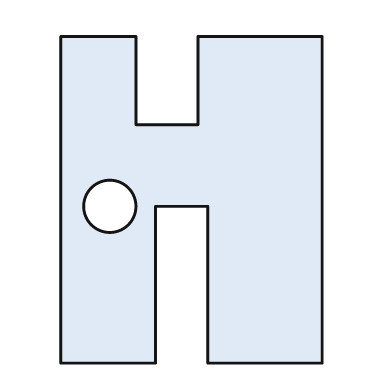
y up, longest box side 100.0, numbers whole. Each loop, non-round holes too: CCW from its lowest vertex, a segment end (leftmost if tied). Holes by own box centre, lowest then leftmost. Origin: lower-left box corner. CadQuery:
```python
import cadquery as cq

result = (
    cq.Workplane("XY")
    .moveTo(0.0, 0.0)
    .lineTo(29.0, 0.0)
    .lineTo(29.0, 48.0)
    .lineTo(45.0, 48.0)
    .lineTo(45.0, 0.0)
    .lineTo(80.0, 0.0)
    .lineTo(80.0, 100.0)
    .lineTo(42.0, 100.0)
    .lineTo(42.0, 73.0)
    .lineTo(23.0, 73.0)
    .lineTo(23.0, 100.0)
    .lineTo(0.0, 100.0)
    .close()
    .moveTo(15.0, 48.0)
    .circle(8.0)
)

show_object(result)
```